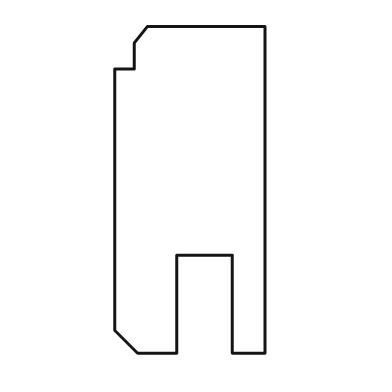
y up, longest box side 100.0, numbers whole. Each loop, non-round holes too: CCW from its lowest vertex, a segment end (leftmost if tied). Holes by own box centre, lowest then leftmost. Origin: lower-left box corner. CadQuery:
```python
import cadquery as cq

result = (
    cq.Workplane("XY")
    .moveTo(7.0, 0.0)
    .lineTo(19.0, 0.0)
    .lineTo(19.0, 30.0)
    .lineTo(36.0, 30.0)
    .lineTo(36.0, 0.0)
    .lineTo(46.0, 0.0)
    .lineTo(46.0, 100.0)
    .lineTo(10.0, 100.0)
    .lineTo(6.0, 95.0)
    .lineTo(6.0, 87.0)
    .lineTo(0.0, 87.0)
    .lineTo(0.0, 7.0)
    .close()
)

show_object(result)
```